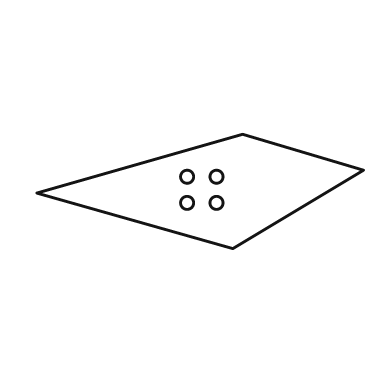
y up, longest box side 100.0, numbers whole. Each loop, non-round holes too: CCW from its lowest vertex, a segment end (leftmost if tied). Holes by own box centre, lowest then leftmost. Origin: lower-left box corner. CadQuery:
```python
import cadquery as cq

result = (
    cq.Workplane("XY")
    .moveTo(60.0, 0.0)
    .lineTo(100.0, 24.0)
    .lineTo(63.0, 35.0)
    .lineTo(0.0, 17.0)
    .close()
    .moveTo(46.0, 14.0)
    .circle(2.0)
    .moveTo(55.0, 14.0)
    .circle(2.0)
    .moveTo(46.0, 22.0)
    .circle(2.0)
    .moveTo(55.0, 22.0)
    .circle(2.0)
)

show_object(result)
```